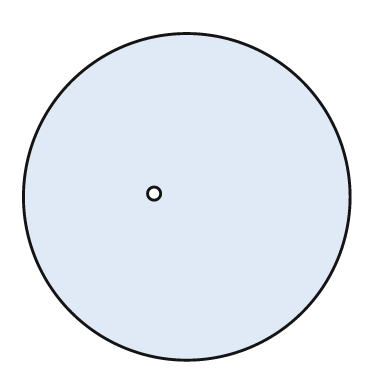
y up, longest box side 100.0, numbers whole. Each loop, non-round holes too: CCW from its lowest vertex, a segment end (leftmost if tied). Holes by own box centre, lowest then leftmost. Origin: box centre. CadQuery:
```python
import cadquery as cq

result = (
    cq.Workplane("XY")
    .moveTo(0.0, 0.0)
    .circle(50.0)
    .moveTo(-10.0, 1.0)
    .circle(2.0)
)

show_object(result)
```